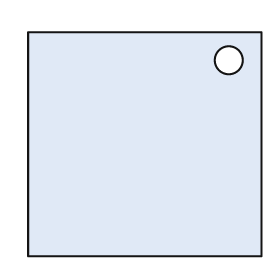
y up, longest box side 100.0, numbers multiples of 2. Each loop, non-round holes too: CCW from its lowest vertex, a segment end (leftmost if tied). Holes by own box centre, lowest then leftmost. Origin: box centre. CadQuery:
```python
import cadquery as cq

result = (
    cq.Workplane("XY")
    .moveTo(-50.0, -48.0)
    .lineTo(50.0, -48.0)
    .lineTo(50.0, 48.0)
    .lineTo(-50.0, 48.0)
    .close()
    .moveTo(36.0, 36.0)
    .circle(6.0)
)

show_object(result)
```